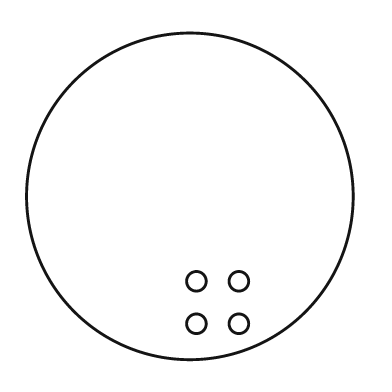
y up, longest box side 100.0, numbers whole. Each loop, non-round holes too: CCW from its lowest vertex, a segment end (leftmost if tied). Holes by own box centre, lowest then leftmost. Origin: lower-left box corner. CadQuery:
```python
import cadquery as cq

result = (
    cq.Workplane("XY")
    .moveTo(50.0, 50.0)
    .circle(50.0)
    .moveTo(52.0, 11.0)
    .circle(3.0)
    .moveTo(65.0, 11.0)
    .circle(3.0)
    .moveTo(52.0, 24.0)
    .circle(3.0)
    .moveTo(65.0, 24.0)
    .circle(3.0)
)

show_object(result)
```